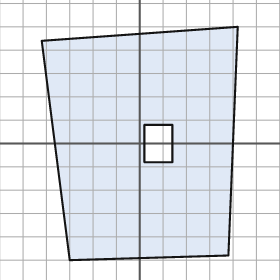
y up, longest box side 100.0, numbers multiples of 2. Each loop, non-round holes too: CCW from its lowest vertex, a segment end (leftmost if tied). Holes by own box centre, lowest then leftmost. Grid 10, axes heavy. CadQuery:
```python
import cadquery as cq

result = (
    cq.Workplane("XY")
    .moveTo(-30.0, -50.0)
    .lineTo(38.0, -48.0)
    .lineTo(42.0, 50.0)
    .lineTo(-42.0, 44.0)
    .close()
    .moveTo(2.0, -8.0)
    .lineTo(14.0, -8.0)
    .lineTo(14.0, 8.0)
    .lineTo(2.0, 8.0)
    .close()
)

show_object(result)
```